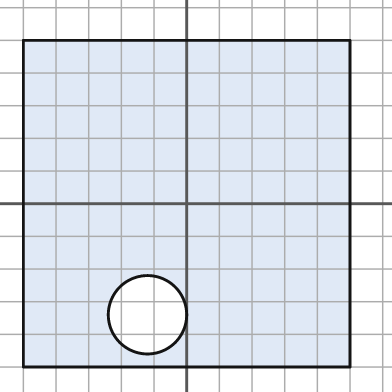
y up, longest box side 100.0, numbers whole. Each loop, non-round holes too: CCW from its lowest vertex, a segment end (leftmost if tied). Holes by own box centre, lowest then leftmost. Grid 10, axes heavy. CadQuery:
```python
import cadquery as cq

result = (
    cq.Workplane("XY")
    .moveTo(-50.0, -50.0)
    .lineTo(50.0, -50.0)
    .lineTo(50.0, 50.0)
    .lineTo(-50.0, 50.0)
    .close()
    .moveTo(-12.0, -34.0)
    .circle(12.0)
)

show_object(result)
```